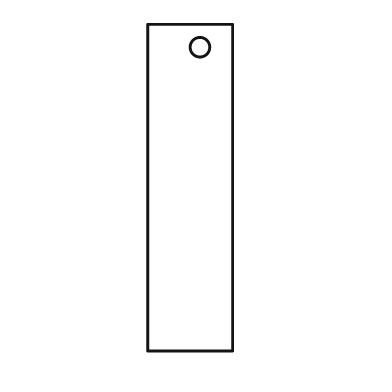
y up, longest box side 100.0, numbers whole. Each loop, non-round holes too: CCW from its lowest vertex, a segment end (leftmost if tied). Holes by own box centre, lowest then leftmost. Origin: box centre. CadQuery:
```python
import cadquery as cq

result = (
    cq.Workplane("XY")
    .moveTo(-13.0, -50.0)
    .lineTo(13.0, -50.0)
    .lineTo(13.0, 50.0)
    .lineTo(-13.0, 50.0)
    .close()
    .moveTo(3.0, 43.0)
    .circle(3.0)
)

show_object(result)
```